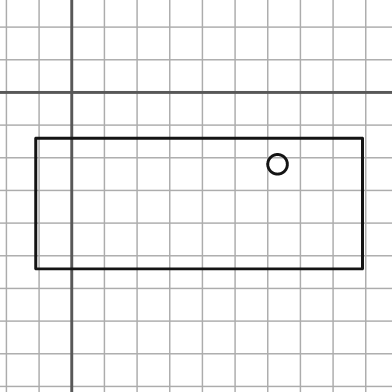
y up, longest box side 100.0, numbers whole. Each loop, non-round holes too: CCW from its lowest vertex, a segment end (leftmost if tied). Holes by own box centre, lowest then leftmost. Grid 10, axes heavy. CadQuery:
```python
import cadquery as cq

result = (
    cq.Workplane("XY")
    .moveTo(-11.0, -54.0)
    .lineTo(89.0, -54.0)
    .lineTo(89.0, -14.0)
    .lineTo(-11.0, -14.0)
    .close()
    .moveTo(63.0, -22.0)
    .circle(3.0)
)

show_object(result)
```